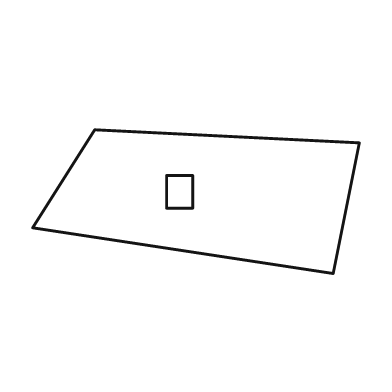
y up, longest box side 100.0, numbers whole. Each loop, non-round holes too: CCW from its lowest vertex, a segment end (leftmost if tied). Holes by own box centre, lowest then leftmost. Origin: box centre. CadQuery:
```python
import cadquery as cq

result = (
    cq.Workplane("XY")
    .moveTo(42.0, -22.0)
    .lineTo(50.0, 18.0)
    .lineTo(-31.0, 22.0)
    .lineTo(-50.0, -8.0)
    .close()
    .moveTo(-9.0, -2.0)
    .lineTo(-1.0, -2.0)
    .lineTo(-1.0, 8.0)
    .lineTo(-9.0, 8.0)
    .close()
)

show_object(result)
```